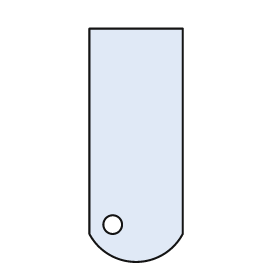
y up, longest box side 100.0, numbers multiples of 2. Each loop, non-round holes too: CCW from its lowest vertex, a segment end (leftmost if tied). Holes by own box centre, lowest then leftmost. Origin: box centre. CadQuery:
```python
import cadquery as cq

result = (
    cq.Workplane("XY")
    .moveTo(-20.0, -38.0)
    .threePointArc((0.0, -50.0), (20.0, -38.0))
    .lineTo(20.0, 50.0)
    .lineTo(-20.0, 50.0)
    .close()
    .moveTo(-10.0, -34.0)
    .circle(4.0)
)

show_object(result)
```